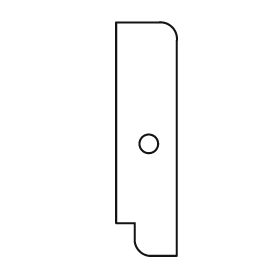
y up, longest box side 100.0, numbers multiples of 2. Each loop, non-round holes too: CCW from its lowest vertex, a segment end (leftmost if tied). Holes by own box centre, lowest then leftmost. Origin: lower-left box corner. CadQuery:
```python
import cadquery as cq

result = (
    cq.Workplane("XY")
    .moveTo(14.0, 0.0)
    .lineTo(26.0, 0.0)
    .lineTo(26.0, 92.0)
    .threePointArc((24.0, 98.0), (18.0, 100.0))
    .lineTo(0.0, 100.0)
    .lineTo(0.0, 14.0)
    .lineTo(8.0, 14.0)
    .lineTo(8.0, 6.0)
    .threePointArc((10.0, 2.0), (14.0, 0.0))
    .close()
    .moveTo(14.0, 48.0)
    .circle(4.0)
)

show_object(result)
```